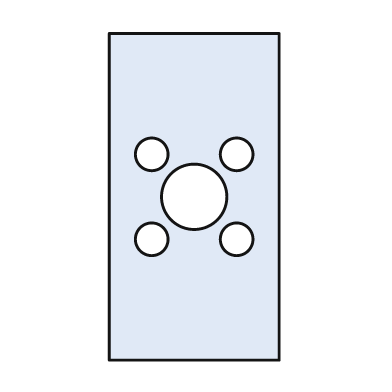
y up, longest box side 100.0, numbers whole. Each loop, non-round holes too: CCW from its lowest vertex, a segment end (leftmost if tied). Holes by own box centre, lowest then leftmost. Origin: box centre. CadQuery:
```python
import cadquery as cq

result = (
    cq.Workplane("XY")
    .moveTo(-26.0, -50.0)
    .lineTo(26.0, -50.0)
    .lineTo(26.0, 50.0)
    .lineTo(-26.0, 50.0)
    .close()
    .moveTo(-13.0, -13.0)
    .circle(5.0)
    .moveTo(13.0, -13.0)
    .circle(5.0)
    .moveTo(0.0, 0.0)
    .circle(10.0)
    .moveTo(-13.0, 13.0)
    .circle(5.0)
    .moveTo(13.0, 13.0)
    .circle(5.0)
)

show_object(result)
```